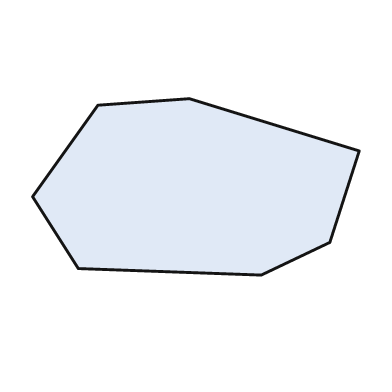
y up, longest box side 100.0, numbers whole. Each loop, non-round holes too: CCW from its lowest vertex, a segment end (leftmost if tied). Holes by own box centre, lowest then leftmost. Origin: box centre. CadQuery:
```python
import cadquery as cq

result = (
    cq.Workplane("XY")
    .moveTo(20.0, -27.0)
    .lineTo(41.0, -17.0)
    .lineTo(50.0, 11.0)
    .lineTo(-2.0, 27.0)
    .lineTo(-30.0, 25.0)
    .lineTo(-50.0, -3.0)
    .lineTo(-36.0, -25.0)
    .close()
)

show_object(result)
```